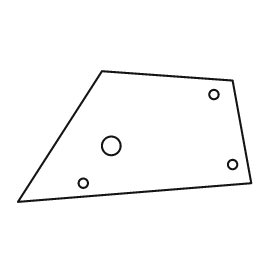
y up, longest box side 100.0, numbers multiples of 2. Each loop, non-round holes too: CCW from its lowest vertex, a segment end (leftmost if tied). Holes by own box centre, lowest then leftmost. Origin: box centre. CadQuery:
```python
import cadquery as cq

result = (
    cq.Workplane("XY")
    .moveTo(-50.0, -28.0)
    .lineTo(50.0, -20.0)
    .lineTo(42.0, 24.0)
    .lineTo(-14.0, 28.0)
    .close()
    .moveTo(-22.0, -20.0)
    .circle(2.0)
    .moveTo(42.0, -12.0)
    .circle(2.0)
    .moveTo(-10.0, -4.0)
    .circle(4.0)
    .moveTo(34.0, 18.0)
    .circle(2.0)
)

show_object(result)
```